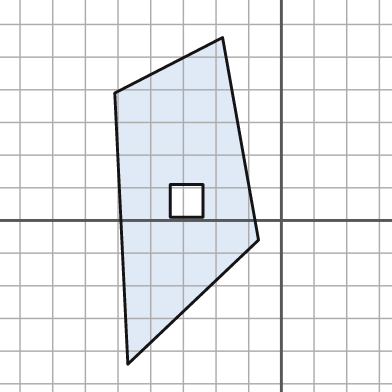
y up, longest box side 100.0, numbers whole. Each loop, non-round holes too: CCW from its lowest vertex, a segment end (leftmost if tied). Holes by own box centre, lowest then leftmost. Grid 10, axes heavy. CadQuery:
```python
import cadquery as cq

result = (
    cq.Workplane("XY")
    .moveTo(-47.0, -44.0)
    .lineTo(-7.0, -6.0)
    .lineTo(-18.0, 56.0)
    .lineTo(-51.0, 39.0)
    .close()
    .moveTo(-34.0, 1.0)
    .lineTo(-24.0, 1.0)
    .lineTo(-24.0, 11.0)
    .lineTo(-34.0, 11.0)
    .close()
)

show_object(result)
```